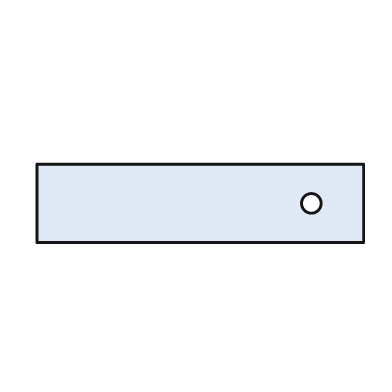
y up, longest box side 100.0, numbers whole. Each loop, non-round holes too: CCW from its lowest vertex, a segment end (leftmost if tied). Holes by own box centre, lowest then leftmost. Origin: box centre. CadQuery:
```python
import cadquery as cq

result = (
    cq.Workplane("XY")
    .moveTo(-50.0, -12.0)
    .lineTo(50.0, -12.0)
    .lineTo(50.0, 12.0)
    .lineTo(-50.0, 12.0)
    .close()
    .moveTo(34.0, 0.0)
    .circle(3.0)
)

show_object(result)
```